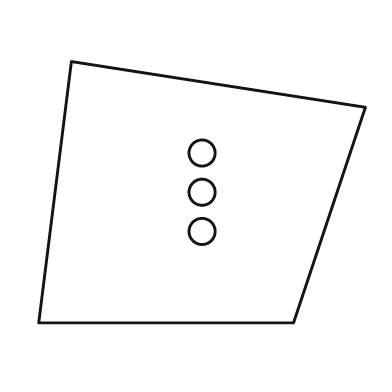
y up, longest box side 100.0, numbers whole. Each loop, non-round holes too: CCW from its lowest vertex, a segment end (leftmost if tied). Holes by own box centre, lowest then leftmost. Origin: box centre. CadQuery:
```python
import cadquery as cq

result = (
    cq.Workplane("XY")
    .moveTo(-50.0, -40.0)
    .lineTo(28.0, -40.0)
    .lineTo(50.0, 26.0)
    .lineTo(-40.0, 40.0)
    .close()
    .moveTo(0.0, -12.0)
    .circle(4.0)
    .moveTo(0.0, 0.0)
    .circle(4.0)
    .moveTo(0.0, 12.0)
    .circle(4.0)
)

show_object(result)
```